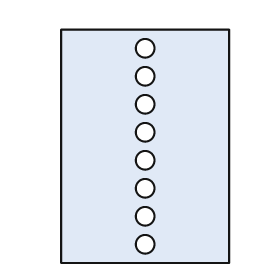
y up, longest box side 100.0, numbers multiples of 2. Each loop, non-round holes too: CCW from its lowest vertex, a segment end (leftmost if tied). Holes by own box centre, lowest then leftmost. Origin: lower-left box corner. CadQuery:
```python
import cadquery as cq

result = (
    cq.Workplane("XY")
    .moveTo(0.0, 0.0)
    .lineTo(72.0, 0.0)
    .lineTo(72.0, 100.0)
    .lineTo(0.0, 100.0)
    .close()
    .moveTo(36.0, 8.0)
    .circle(4.0)
    .moveTo(36.0, 20.0)
    .circle(4.0)
    .moveTo(36.0, 32.0)
    .circle(4.0)
    .moveTo(36.0, 44.0)
    .circle(4.0)
    .moveTo(36.0, 56.0)
    .circle(4.0)
    .moveTo(36.0, 68.0)
    .circle(4.0)
    .moveTo(36.0, 80.0)
    .circle(4.0)
    .moveTo(36.0, 92.0)
    .circle(4.0)
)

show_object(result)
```